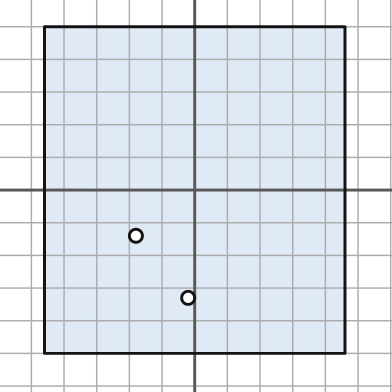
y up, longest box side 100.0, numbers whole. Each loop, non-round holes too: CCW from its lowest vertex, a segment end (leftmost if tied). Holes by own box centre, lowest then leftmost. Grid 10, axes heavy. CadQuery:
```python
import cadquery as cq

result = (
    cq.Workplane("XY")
    .moveTo(-46.0, -50.0)
    .lineTo(46.0, -50.0)
    .lineTo(46.0, 50.0)
    .lineTo(-46.0, 50.0)
    .close()
    .moveTo(-2.0, -33.0)
    .circle(2.0)
    .moveTo(-18.0, -14.0)
    .circle(2.0)
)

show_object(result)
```